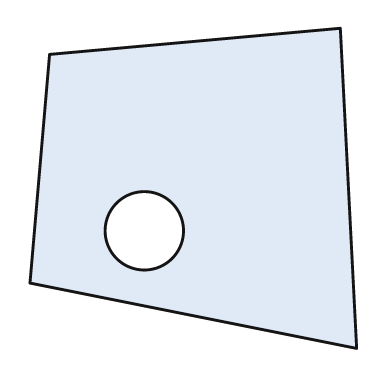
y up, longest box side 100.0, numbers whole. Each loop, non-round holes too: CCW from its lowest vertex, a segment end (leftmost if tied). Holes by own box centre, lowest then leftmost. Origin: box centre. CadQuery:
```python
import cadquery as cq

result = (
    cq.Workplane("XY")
    .moveTo(50.0, -49.0)
    .lineTo(45.0, 49.0)
    .lineTo(-44.0, 41.0)
    .lineTo(-50.0, -29.0)
    .close()
    .moveTo(-15.0, -13.0)
    .circle(12.0)
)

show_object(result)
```